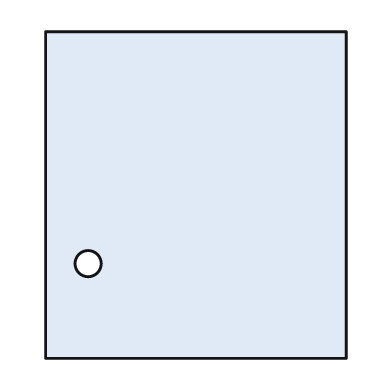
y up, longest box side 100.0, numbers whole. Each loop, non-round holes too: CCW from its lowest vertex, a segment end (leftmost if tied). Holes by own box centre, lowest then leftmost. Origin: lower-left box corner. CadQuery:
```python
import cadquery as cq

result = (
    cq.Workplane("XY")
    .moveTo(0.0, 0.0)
    .lineTo(92.0, 0.0)
    .lineTo(92.0, 100.0)
    .lineTo(0.0, 100.0)
    .close()
    .moveTo(13.0, 29.0)
    .circle(4.0)
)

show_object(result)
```